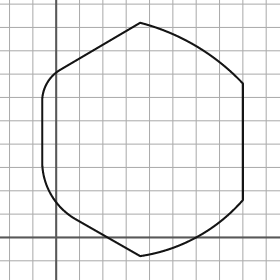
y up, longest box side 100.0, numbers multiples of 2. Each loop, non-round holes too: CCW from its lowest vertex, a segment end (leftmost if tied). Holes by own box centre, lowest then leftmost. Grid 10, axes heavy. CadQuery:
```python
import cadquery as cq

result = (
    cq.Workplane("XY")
    .moveTo(36.0, -8.0)
    .threePointArc((60.0, 0.0), (80.0, 16.0))
    .lineTo(80.0, 66.0)
    .threePointArc((60.0, 82.0), (36.0, 92.0))
    .lineTo(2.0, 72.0)
    .threePointArc((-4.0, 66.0), (-6.0, 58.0))
    .lineTo(-6.0, 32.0)
    .threePointArc((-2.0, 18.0), (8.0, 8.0))
    .close()
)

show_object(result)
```